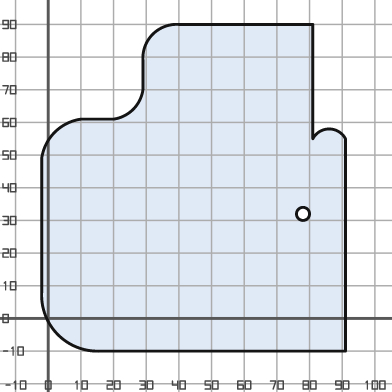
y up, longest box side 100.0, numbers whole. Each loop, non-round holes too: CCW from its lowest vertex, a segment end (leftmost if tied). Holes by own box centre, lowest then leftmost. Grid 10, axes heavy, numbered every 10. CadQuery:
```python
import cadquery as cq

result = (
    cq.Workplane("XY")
    .moveTo(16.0, -10.0)
    .lineTo(91.0, -10.0)
    .lineTo(91.0, 55.0)
    .threePointArc((86.0, 58.0), (81.0, 55.0))
    .lineTo(81.0, 90.0)
    .lineTo(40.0, 90.0)
    .threePointArc((32.0, 87.0), (29.0, 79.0))
    .lineTo(29.0, 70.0)
    .threePointArc((26.0, 64.0), (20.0, 61.0))
    .lineTo(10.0, 61.0)
    .threePointArc((2.0, 57.0), (-2.0, 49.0))
    .lineTo(-2.0, 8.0)
    .threePointArc((3.0, -5.0), (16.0, -10.0))
    .close()
    .moveTo(78.0, 32.0)
    .circle(2.0)
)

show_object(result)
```